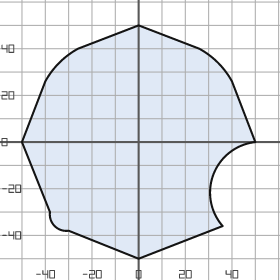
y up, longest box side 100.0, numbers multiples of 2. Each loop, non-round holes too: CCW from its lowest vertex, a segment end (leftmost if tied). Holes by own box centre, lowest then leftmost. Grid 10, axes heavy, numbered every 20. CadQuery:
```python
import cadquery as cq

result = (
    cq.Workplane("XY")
    .moveTo(0.0, -50.0)
    .lineTo(36.0, -36.0)
    .threePointArc((32.0, -14.0), (50.0, 0.0))
    .lineTo(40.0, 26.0)
    .threePointArc((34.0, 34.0), (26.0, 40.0))
    .lineTo(0.0, 50.0)
    .lineTo(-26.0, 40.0)
    .threePointArc((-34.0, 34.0), (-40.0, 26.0))
    .lineTo(-50.0, 0.0)
    .lineTo(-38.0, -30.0)
    .threePointArc((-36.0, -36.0), (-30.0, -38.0))
    .close()
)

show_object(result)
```